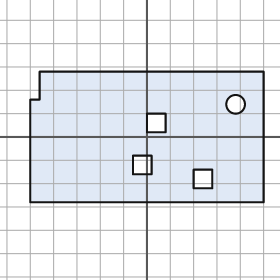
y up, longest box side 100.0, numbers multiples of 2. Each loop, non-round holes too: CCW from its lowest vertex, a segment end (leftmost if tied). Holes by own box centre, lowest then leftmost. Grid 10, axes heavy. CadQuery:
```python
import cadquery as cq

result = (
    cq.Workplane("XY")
    .moveTo(-50.0, -28.0)
    .lineTo(50.0, -28.0)
    .lineTo(50.0, 28.0)
    .lineTo(-46.0, 28.0)
    .lineTo(-46.0, 16.0)
    .lineTo(-50.0, 16.0)
    .close()
    .moveTo(20.0, -22.0)
    .lineTo(28.0, -22.0)
    .lineTo(28.0, -14.0)
    .lineTo(20.0, -14.0)
    .close()
    .moveTo(-6.0, -16.0)
    .lineTo(2.0, -16.0)
    .lineTo(2.0, -8.0)
    .lineTo(-6.0, -8.0)
    .close()
    .moveTo(0.0, 2.0)
    .lineTo(8.0, 2.0)
    .lineTo(8.0, 10.0)
    .lineTo(0.0, 10.0)
    .close()
    .moveTo(38.0, 14.0)
    .circle(4.0)
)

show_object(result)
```